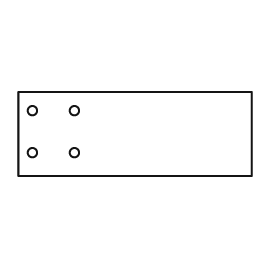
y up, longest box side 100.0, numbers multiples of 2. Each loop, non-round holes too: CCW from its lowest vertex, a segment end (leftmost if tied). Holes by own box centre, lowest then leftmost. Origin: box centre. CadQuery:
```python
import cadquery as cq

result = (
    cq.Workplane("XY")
    .moveTo(-50.0, -18.0)
    .lineTo(50.0, -18.0)
    .lineTo(50.0, 18.0)
    .lineTo(-50.0, 18.0)
    .close()
    .moveTo(-44.0, -8.0)
    .circle(2.0)
    .moveTo(-26.0, -8.0)
    .circle(2.0)
    .moveTo(-44.0, 10.0)
    .circle(2.0)
    .moveTo(-26.0, 10.0)
    .circle(2.0)
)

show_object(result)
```